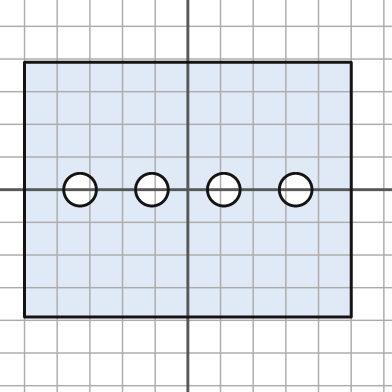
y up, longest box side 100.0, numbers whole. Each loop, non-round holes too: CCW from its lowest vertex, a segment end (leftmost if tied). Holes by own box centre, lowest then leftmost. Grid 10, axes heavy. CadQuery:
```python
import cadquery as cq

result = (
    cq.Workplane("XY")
    .moveTo(-50.0, -39.0)
    .lineTo(50.0, -39.0)
    .lineTo(50.0, 39.0)
    .lineTo(-50.0, 39.0)
    .close()
    .moveTo(-33.0, 0.0)
    .circle(5.0)
    .moveTo(-11.0, 0.0)
    .circle(5.0)
    .moveTo(11.0, 0.0)
    .circle(5.0)
    .moveTo(33.0, 0.0)
    .circle(5.0)
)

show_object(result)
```